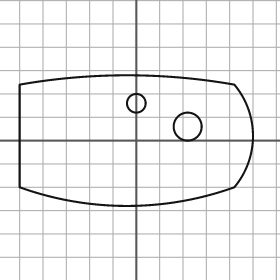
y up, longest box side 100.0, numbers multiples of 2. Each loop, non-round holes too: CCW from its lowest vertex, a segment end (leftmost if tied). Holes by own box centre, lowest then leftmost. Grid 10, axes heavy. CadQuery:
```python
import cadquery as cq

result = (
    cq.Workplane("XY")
    .moveTo(-50.0, -20.0)
    .threePointArc((-4.0, -28.0), (42.0, -20.0))
    .threePointArc((50.0, 2.0), (42.0, 24.0))
    .threePointArc((-4.0, 28.0), (-50.0, 24.0))
    .close()
    .moveTo(22.0, 6.0)
    .circle(6.0)
    .moveTo(0.0, 16.0)
    .circle(4.0)
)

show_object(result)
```